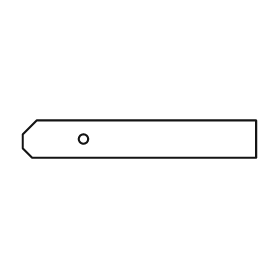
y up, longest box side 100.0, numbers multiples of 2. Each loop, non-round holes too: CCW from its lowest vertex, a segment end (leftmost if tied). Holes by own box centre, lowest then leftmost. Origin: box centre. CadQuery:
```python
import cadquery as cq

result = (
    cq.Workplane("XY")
    .moveTo(-46.0, -8.0)
    .lineTo(50.0, -8.0)
    .lineTo(50.0, 8.0)
    .lineTo(-44.0, 8.0)
    .lineTo(-50.0, 2.0)
    .lineTo(-50.0, -4.0)
    .close()
    .moveTo(-24.0, 0.0)
    .circle(2.0)
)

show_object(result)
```